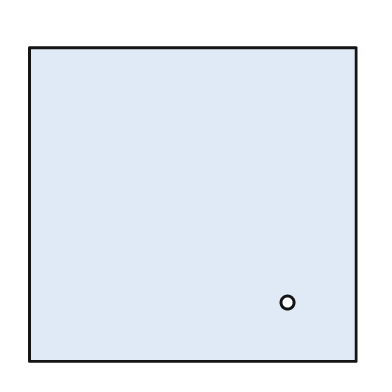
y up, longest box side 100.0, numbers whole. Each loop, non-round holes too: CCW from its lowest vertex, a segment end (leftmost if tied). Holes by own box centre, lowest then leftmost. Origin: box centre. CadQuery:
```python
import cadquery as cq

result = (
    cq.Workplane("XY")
    .moveTo(-50.0, -48.0)
    .lineTo(50.0, -48.0)
    .lineTo(50.0, 48.0)
    .lineTo(-50.0, 48.0)
    .close()
    .moveTo(29.0, -30.0)
    .circle(2.0)
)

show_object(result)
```